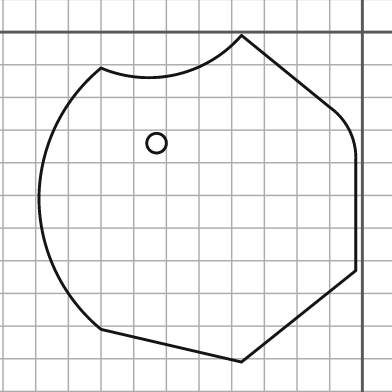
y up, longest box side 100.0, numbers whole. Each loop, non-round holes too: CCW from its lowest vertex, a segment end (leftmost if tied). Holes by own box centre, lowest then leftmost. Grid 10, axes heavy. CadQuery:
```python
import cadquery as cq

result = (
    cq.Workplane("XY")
    .moveTo(-37.0, -101.0)
    .lineTo(-2.0, -73.0)
    .lineTo(-2.0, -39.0)
    .threePointArc((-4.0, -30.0), (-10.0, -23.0))
    .lineTo(-37.0, -1.0)
    .threePointArc((-57.0, -13.0), (-80.0, -11.0))
    .threePointArc((-94.0, -29.0), (-99.0, -51.0))
    .threePointArc((-94.0, -73.0), (-80.0, -91.0))
    .close()
    .moveTo(-63.0, -34.0)
    .circle(3.0)
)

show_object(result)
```